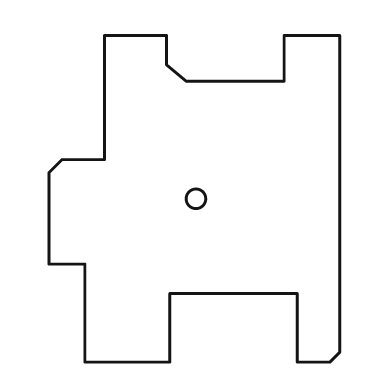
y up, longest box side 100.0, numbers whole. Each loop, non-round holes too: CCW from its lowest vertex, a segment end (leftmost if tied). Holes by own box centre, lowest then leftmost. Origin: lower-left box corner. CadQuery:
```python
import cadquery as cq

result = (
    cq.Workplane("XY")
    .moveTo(11.0, 0.0)
    .lineTo(37.0, 0.0)
    .lineTo(37.0, 21.0)
    .lineTo(76.0, 21.0)
    .lineTo(76.0, 0.0)
    .lineTo(86.0, 0.0)
    .lineTo(89.0, 3.0)
    .lineTo(89.0, 100.0)
    .lineTo(72.0, 100.0)
    .lineTo(72.0, 86.0)
    .lineTo(42.0, 86.0)
    .lineTo(36.0, 91.0)
    .lineTo(36.0, 100.0)
    .lineTo(17.0, 100.0)
    .lineTo(17.0, 62.0)
    .lineTo(4.0, 62.0)
    .lineTo(0.0, 58.0)
    .lineTo(0.0, 30.0)
    .lineTo(11.0, 30.0)
    .close()
    .moveTo(45.0, 50.0)
    .circle(3.0)
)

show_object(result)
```